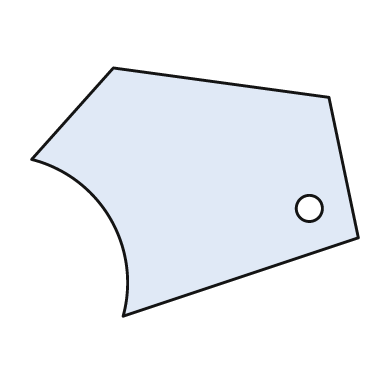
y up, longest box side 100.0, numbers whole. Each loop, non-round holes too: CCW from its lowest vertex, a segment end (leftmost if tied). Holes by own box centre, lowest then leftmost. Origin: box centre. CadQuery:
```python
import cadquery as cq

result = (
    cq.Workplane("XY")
    .moveTo(-22.0, -38.0)
    .lineTo(50.0, -14.0)
    .lineTo(41.0, 29.0)
    .lineTo(-25.0, 38.0)
    .lineTo(-50.0, 10.0)
    .threePointArc((-26.0, -8.0), (-22.0, -38.0))
    .close()
    .moveTo(35.0, -5.0)
    .circle(4.0)
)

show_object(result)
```